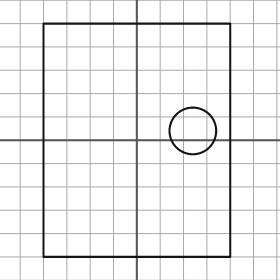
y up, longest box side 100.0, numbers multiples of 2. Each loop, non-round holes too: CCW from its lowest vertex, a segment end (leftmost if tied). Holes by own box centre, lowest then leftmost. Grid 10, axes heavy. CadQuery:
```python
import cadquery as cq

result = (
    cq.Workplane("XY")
    .moveTo(-40.0, -50.0)
    .lineTo(40.0, -50.0)
    .lineTo(40.0, 50.0)
    .lineTo(-40.0, 50.0)
    .close()
    .moveTo(24.0, 4.0)
    .circle(10.0)
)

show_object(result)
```